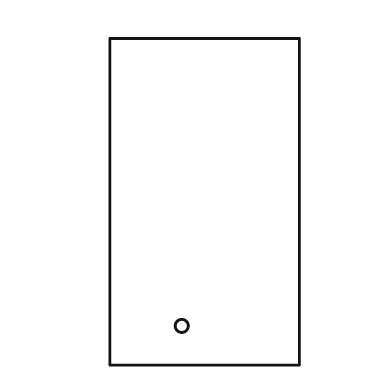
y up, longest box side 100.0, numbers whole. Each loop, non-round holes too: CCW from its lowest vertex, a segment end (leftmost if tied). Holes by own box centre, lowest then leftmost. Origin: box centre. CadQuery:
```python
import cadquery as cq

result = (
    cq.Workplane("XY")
    .moveTo(-29.0, -50.0)
    .lineTo(29.0, -50.0)
    .lineTo(29.0, 50.0)
    .lineTo(-29.0, 50.0)
    .close()
    .moveTo(-7.0, -38.0)
    .circle(2.0)
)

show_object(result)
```